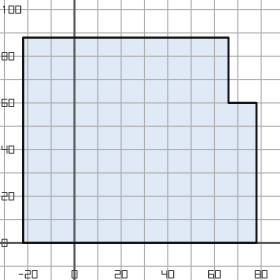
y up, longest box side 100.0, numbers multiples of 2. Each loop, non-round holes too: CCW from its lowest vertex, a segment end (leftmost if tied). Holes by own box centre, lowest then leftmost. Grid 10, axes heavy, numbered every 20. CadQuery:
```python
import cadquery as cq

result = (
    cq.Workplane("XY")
    .moveTo(-22.0, 0.0)
    .lineTo(78.0, 0.0)
    .lineTo(78.0, 60.0)
    .lineTo(66.0, 60.0)
    .lineTo(66.0, 88.0)
    .lineTo(-22.0, 88.0)
    .close()
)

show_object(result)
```